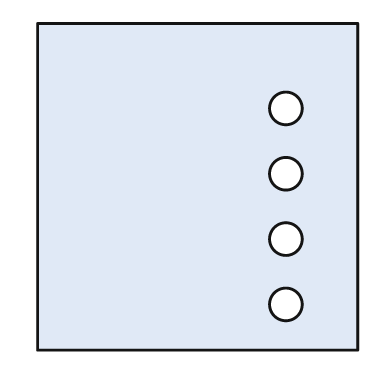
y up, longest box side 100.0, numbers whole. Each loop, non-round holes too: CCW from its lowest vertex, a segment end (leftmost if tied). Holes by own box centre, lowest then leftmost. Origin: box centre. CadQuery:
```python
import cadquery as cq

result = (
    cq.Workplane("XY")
    .moveTo(-49.0, -50.0)
    .lineTo(49.0, -50.0)
    .lineTo(49.0, 50.0)
    .lineTo(-49.0, 50.0)
    .close()
    .moveTo(27.0, -36.0)
    .circle(5.0)
    .moveTo(27.0, -16.0)
    .circle(5.0)
    .moveTo(27.0, 4.0)
    .circle(5.0)
    .moveTo(27.0, 24.0)
    .circle(5.0)
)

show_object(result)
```